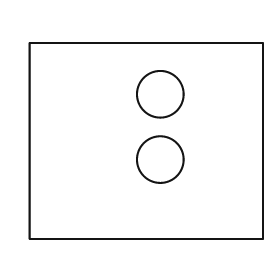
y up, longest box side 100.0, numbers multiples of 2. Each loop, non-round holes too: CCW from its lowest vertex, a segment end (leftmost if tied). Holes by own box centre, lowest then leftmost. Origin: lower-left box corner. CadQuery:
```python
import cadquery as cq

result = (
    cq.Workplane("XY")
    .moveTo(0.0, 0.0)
    .lineTo(100.0, 0.0)
    .lineTo(100.0, 84.0)
    .lineTo(0.0, 84.0)
    .close()
    .moveTo(56.0, 34.0)
    .circle(10.0)
    .moveTo(56.0, 62.0)
    .circle(10.0)
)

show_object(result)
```